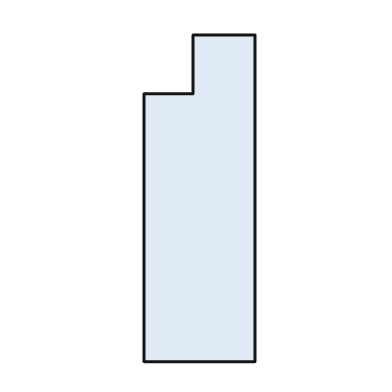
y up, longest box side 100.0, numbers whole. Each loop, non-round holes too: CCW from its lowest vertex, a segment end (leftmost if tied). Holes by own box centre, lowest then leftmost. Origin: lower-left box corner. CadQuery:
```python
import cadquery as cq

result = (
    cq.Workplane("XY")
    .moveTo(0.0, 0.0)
    .lineTo(34.0, 0.0)
    .lineTo(34.0, 100.0)
    .lineTo(15.0, 100.0)
    .lineTo(15.0, 82.0)
    .lineTo(0.0, 82.0)
    .close()
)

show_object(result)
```